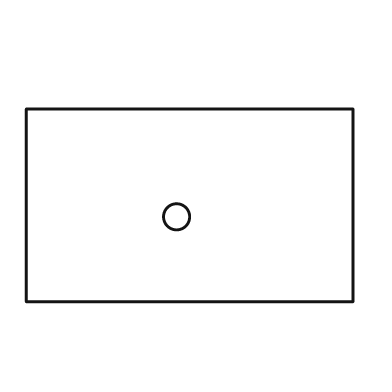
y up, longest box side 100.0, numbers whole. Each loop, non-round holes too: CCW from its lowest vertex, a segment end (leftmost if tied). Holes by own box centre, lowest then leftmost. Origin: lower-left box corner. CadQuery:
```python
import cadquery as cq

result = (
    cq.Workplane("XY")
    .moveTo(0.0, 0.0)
    .lineTo(100.0, 0.0)
    .lineTo(100.0, 59.0)
    .lineTo(0.0, 59.0)
    .close()
    .moveTo(46.0, 26.0)
    .circle(4.0)
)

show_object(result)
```